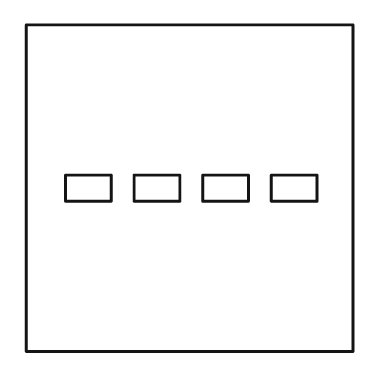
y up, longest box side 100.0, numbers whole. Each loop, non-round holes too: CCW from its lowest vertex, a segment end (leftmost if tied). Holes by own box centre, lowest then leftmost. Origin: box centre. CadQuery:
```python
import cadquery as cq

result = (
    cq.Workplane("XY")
    .moveTo(-50.0, -50.0)
    .lineTo(50.0, -50.0)
    .lineTo(50.0, 50.0)
    .lineTo(-50.0, 50.0)
    .close()
    .moveTo(-38.0, -4.0)
    .lineTo(-24.0, -4.0)
    .lineTo(-24.0, 4.0)
    .lineTo(-38.0, 4.0)
    .close()
    .moveTo(-17.0, -4.0)
    .lineTo(-3.0, -4.0)
    .lineTo(-3.0, 4.0)
    .lineTo(-17.0, 4.0)
    .close()
    .moveTo(4.0, -4.0)
    .lineTo(18.0, -4.0)
    .lineTo(18.0, 4.0)
    .lineTo(4.0, 4.0)
    .close()
    .moveTo(25.0, -4.0)
    .lineTo(39.0, -4.0)
    .lineTo(39.0, 4.0)
    .lineTo(25.0, 4.0)
    .close()
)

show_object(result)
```